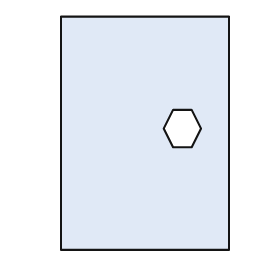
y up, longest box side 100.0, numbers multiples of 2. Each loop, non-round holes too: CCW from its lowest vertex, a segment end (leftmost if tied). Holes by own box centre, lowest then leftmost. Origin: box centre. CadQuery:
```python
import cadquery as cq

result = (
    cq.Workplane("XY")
    .moveTo(-36.0, -50.0)
    .lineTo(36.0, -50.0)
    .lineTo(36.0, 50.0)
    .lineTo(-36.0, 50.0)
    .close()
    .moveTo(12.0, -6.0)
    .lineTo(20.0, -6.0)
    .lineTo(24.0, 2.0)
    .lineTo(20.0, 10.0)
    .lineTo(12.0, 10.0)
    .lineTo(8.0, 2.0)
    .close()
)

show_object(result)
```